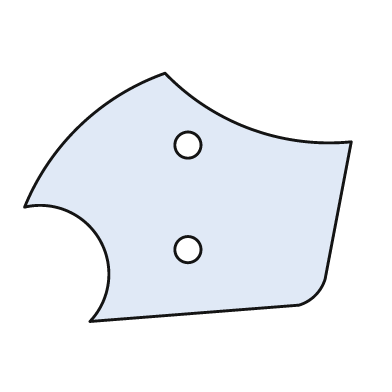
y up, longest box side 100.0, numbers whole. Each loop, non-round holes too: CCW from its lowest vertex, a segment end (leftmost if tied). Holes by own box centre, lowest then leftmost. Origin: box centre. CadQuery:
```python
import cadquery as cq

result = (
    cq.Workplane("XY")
    .moveTo(-30.0, -38.0)
    .lineTo(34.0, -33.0)
    .threePointArc((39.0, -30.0), (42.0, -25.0))
    .lineTo(50.0, 17.0)
    .threePointArc((19.0, 21.0), (-7.0, 38.0))
    .threePointArc((-33.0, 22.0), (-50.0, -3.0))
    .threePointArc((-27.0, -13.0), (-30.0, -38.0))
    .close()
    .moveTo(0.0, -16.0)
    .circle(4.0)
    .moveTo(0.0, 16.0)
    .circle(4.0)
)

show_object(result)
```